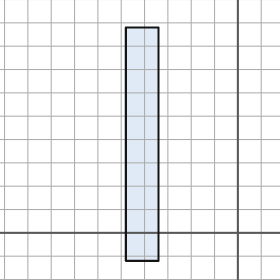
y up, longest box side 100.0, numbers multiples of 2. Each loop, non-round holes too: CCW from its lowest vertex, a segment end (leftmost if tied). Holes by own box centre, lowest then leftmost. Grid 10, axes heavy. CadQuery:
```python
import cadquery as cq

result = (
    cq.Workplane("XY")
    .moveTo(-48.0, -12.0)
    .lineTo(-34.0, -12.0)
    .lineTo(-34.0, 88.0)
    .lineTo(-48.0, 88.0)
    .close()
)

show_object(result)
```